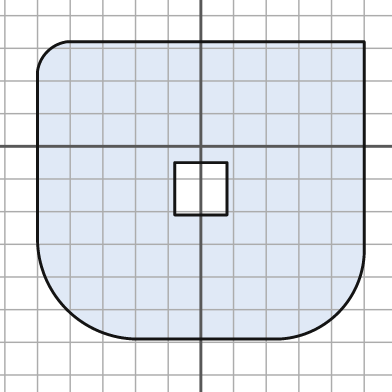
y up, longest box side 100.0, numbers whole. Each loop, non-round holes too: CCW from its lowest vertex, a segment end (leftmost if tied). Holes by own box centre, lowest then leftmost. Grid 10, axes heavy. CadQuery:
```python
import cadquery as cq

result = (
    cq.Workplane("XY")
    .moveTo(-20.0, -59.0)
    .lineTo(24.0, -59.0)
    .threePointArc((42.0, -51.0), (50.0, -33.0))
    .lineTo(50.0, 32.0)
    .lineTo(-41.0, 32.0)
    .threePointArc((-47.0, 29.0), (-50.0, 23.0))
    .lineTo(-50.0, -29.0)
    .threePointArc((-41.0, -50.0), (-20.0, -59.0))
    .close()
    .moveTo(-8.0, -21.0)
    .lineTo(8.0, -21.0)
    .lineTo(8.0, -5.0)
    .lineTo(-8.0, -5.0)
    .close()
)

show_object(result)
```